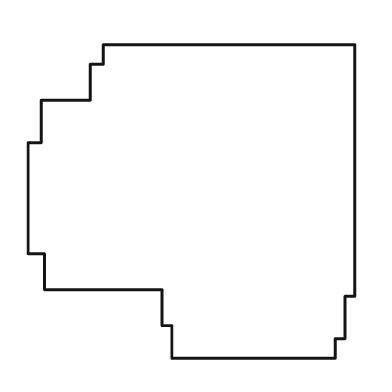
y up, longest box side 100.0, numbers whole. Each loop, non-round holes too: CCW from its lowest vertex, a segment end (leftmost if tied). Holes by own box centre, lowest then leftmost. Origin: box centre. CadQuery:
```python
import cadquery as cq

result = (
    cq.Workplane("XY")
    .moveTo(-6.0, -48.0)
    .lineTo(44.0, -48.0)
    .lineTo(44.0, -42.0)
    .lineTo(47.0, -42.0)
    .lineTo(47.0, -29.0)
    .lineTo(50.0, -29.0)
    .lineTo(50.0, 48.0)
    .lineTo(-27.0, 48.0)
    .lineTo(-27.0, 42.0)
    .lineTo(-31.0, 42.0)
    .lineTo(-31.0, 31.0)
    .lineTo(-46.0, 31.0)
    .lineTo(-46.0, 18.0)
    .lineTo(-50.0, 18.0)
    .lineTo(-50.0, -16.0)
    .lineTo(-45.0, -16.0)
    .lineTo(-45.0, -27.0)
    .lineTo(-9.0, -27.0)
    .lineTo(-9.0, -38.0)
    .lineTo(-6.0, -38.0)
    .close()
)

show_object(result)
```